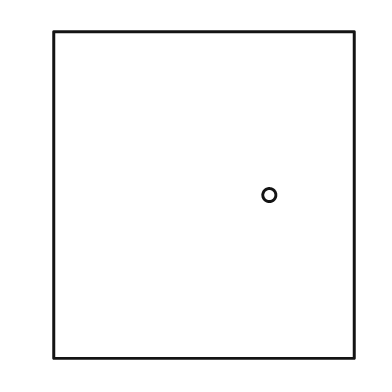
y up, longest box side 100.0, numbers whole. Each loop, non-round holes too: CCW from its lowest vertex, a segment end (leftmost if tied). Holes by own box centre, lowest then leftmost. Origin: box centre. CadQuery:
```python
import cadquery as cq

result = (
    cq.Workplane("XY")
    .moveTo(-46.0, -50.0)
    .lineTo(46.0, -50.0)
    .lineTo(46.0, 50.0)
    .lineTo(-46.0, 50.0)
    .close()
    .moveTo(20.0, 0.0)
    .circle(2.0)
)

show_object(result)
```